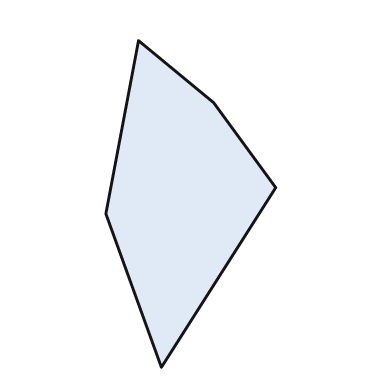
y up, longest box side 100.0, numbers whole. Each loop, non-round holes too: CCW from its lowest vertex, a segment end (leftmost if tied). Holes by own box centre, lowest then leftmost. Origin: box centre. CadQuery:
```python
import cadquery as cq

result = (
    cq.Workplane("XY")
    .moveTo(-9.0, -50.0)
    .lineTo(26.0, 5.0)
    .lineTo(7.0, 31.0)
    .lineTo(-16.0, 50.0)
    .lineTo(-26.0, -3.0)
    .close()
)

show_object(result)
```